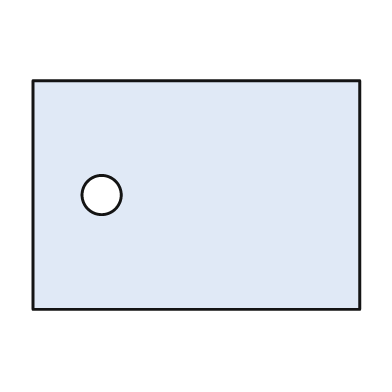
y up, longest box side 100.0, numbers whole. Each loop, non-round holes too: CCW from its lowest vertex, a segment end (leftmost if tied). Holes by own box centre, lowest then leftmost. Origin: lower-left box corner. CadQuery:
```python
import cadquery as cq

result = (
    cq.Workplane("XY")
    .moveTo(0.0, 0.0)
    .lineTo(100.0, 0.0)
    .lineTo(100.0, 70.0)
    .lineTo(0.0, 70.0)
    .close()
    .moveTo(21.0, 35.0)
    .circle(6.0)
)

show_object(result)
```